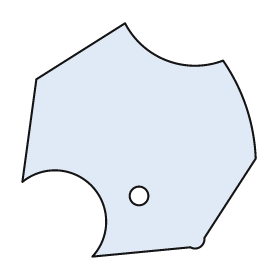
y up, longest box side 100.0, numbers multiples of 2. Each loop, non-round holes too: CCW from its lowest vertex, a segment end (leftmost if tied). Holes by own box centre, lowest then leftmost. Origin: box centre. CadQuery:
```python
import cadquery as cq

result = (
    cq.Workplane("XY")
    .moveTo(-20.0, -50.0)
    .lineTo(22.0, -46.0)
    .threePointArc((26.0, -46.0), (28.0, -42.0))
    .lineTo(50.0, -8.0)
    .threePointArc((46.0, 14.0), (36.0, 34.0))
    .threePointArc((12.0, 34.0), (-6.0, 50.0))
    .lineTo(-44.0, 26.0)
    .lineTo(-50.0, -18.0)
    .threePointArc((-20.0, -20.0), (-20.0, -50.0))
    .close()
    .moveTo(0.0, -24.0)
    .circle(4.0)
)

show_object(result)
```